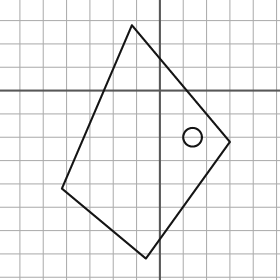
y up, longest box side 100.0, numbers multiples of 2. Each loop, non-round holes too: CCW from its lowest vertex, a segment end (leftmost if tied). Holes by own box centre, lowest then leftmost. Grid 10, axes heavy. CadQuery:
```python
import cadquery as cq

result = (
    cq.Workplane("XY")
    .moveTo(-6.0, -72.0)
    .lineTo(30.0, -22.0)
    .lineTo(-12.0, 28.0)
    .lineTo(-42.0, -42.0)
    .close()
    .moveTo(14.0, -20.0)
    .circle(4.0)
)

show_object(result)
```